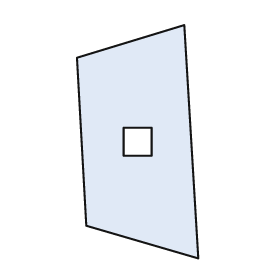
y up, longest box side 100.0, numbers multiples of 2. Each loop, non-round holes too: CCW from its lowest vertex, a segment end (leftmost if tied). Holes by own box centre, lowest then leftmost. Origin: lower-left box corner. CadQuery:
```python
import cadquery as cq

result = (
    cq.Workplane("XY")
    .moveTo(52.0, 0.0)
    .lineTo(46.0, 100.0)
    .lineTo(0.0, 86.0)
    .lineTo(4.0, 14.0)
    .close()
    .moveTo(20.0, 44.0)
    .lineTo(32.0, 44.0)
    .lineTo(32.0, 56.0)
    .lineTo(20.0, 56.0)
    .close()
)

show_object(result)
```